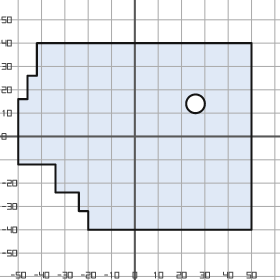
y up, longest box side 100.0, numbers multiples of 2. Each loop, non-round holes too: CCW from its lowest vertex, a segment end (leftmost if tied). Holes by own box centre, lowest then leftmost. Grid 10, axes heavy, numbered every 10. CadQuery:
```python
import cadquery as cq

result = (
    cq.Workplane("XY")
    .moveTo(-20.0, -40.0)
    .lineTo(50.0, -40.0)
    .lineTo(50.0, 40.0)
    .lineTo(-42.0, 40.0)
    .lineTo(-42.0, 26.0)
    .lineTo(-46.0, 26.0)
    .lineTo(-46.0, 16.0)
    .lineTo(-50.0, 16.0)
    .lineTo(-50.0, -12.0)
    .lineTo(-34.0, -12.0)
    .lineTo(-34.0, -24.0)
    .lineTo(-24.0, -24.0)
    .lineTo(-24.0, -32.0)
    .lineTo(-20.0, -32.0)
    .close()
    .moveTo(26.0, 14.0)
    .circle(4.0)
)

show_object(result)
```